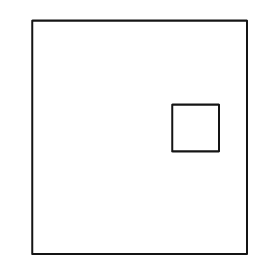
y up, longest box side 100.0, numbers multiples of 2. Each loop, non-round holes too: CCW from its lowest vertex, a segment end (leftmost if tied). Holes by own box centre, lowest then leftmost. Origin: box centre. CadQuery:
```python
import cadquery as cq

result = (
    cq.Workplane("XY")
    .moveTo(-46.0, -50.0)
    .lineTo(46.0, -50.0)
    .lineTo(46.0, 50.0)
    .lineTo(-46.0, 50.0)
    .close()
    .moveTo(14.0, -6.0)
    .lineTo(34.0, -6.0)
    .lineTo(34.0, 14.0)
    .lineTo(14.0, 14.0)
    .close()
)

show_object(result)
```